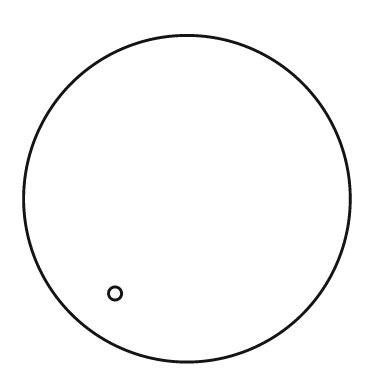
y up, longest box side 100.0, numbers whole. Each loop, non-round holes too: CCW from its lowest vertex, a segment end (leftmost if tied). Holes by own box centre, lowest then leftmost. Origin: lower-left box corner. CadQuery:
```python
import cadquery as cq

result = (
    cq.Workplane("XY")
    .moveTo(50.0, 50.0)
    .circle(50.0)
    .moveTo(28.0, 21.0)
    .circle(2.0)
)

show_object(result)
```